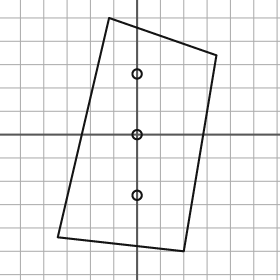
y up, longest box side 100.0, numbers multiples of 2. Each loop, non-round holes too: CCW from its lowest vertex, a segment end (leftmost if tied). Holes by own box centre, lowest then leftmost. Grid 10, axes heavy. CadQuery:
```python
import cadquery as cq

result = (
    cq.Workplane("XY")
    .moveTo(20.0, -50.0)
    .lineTo(34.0, 34.0)
    .lineTo(-12.0, 50.0)
    .lineTo(-34.0, -44.0)
    .close()
    .moveTo(0.0, -26.0)
    .circle(2.0)
    .moveTo(0.0, 0.0)
    .circle(2.0)
    .moveTo(0.0, 26.0)
    .circle(2.0)
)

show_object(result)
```